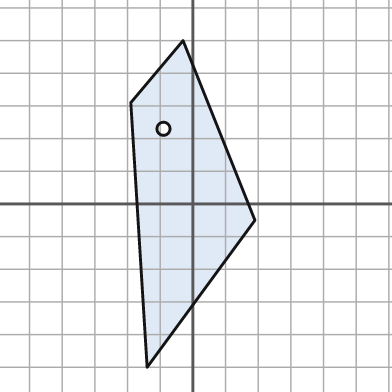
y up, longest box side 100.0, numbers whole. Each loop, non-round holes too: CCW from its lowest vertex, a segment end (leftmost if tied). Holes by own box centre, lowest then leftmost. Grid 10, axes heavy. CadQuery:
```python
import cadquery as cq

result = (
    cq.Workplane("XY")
    .moveTo(-14.0, -50.0)
    .lineTo(19.0, -5.0)
    .lineTo(-3.0, 50.0)
    .lineTo(-19.0, 31.0)
    .close()
    .moveTo(-9.0, 23.0)
    .circle(2.0)
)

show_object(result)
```